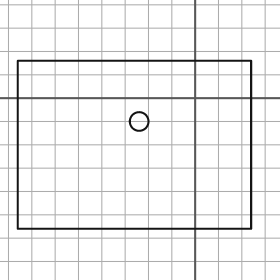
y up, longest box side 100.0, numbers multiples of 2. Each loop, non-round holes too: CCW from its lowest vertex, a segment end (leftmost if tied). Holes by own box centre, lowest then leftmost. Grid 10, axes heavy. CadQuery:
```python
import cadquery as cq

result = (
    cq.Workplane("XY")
    .moveTo(-76.0, -56.0)
    .lineTo(24.0, -56.0)
    .lineTo(24.0, 16.0)
    .lineTo(-76.0, 16.0)
    .close()
    .moveTo(-24.0, -10.0)
    .circle(4.0)
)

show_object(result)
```